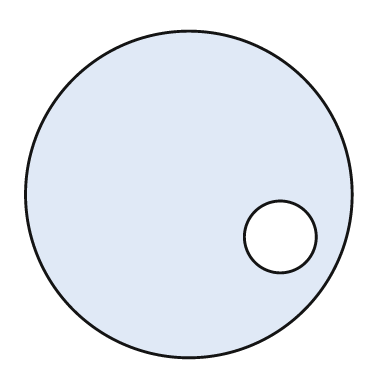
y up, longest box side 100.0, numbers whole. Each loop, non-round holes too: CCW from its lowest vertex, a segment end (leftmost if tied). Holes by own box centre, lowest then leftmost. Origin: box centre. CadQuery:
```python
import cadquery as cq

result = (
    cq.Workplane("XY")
    .moveTo(0.0, 0.0)
    .circle(50.0)
    .moveTo(28.0, -13.0)
    .circle(11.0)
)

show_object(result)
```